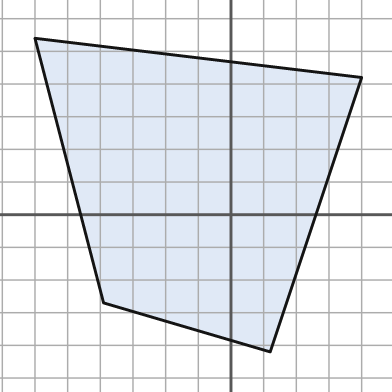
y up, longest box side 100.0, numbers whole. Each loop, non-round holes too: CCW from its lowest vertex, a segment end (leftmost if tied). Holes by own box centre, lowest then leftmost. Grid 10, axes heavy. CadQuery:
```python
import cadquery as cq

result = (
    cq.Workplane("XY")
    .moveTo(12.0, -42.0)
    .lineTo(40.0, 42.0)
    .lineTo(-60.0, 54.0)
    .lineTo(-39.0, -27.0)
    .close()
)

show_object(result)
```